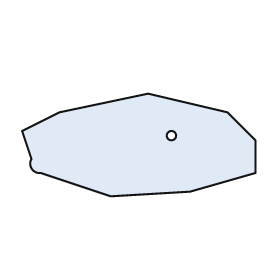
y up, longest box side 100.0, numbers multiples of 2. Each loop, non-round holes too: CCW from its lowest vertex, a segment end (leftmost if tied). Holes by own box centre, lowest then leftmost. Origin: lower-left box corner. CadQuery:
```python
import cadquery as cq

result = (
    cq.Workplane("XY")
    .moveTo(38.0, 0.0)
    .lineTo(72.0, 2.0)
    .lineTo(100.0, 10.0)
    .lineTo(100.0, 24.0)
    .lineTo(88.0, 36.0)
    .lineTo(54.0, 44.0)
    .lineTo(16.0, 36.0)
    .lineTo(0.0, 28.0)
    .lineTo(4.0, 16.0)
    .threePointArc((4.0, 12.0), (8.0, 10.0))
    .close()
    .moveTo(64.0, 26.0)
    .circle(2.0)
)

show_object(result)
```